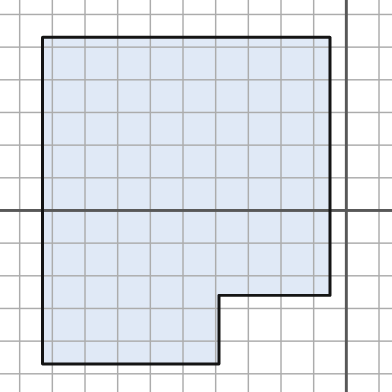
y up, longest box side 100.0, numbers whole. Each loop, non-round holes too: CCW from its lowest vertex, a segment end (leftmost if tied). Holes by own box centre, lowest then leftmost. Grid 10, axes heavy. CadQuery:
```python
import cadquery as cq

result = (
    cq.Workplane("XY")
    .moveTo(-93.0, -47.0)
    .lineTo(-39.0, -47.0)
    .lineTo(-39.0, -26.0)
    .lineTo(-5.0, -26.0)
    .lineTo(-5.0, 53.0)
    .lineTo(-93.0, 53.0)
    .close()
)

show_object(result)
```